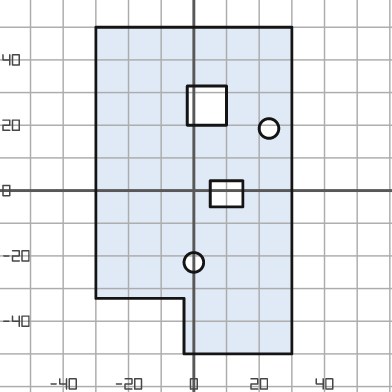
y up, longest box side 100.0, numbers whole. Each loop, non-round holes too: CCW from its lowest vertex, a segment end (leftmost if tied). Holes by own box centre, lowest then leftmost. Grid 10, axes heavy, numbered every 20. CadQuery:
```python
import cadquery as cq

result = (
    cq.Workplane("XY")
    .moveTo(-3.0, -50.0)
    .lineTo(30.0, -50.0)
    .lineTo(30.0, 50.0)
    .lineTo(-30.0, 50.0)
    .lineTo(-30.0, -33.0)
    .lineTo(-3.0, -33.0)
    .close()
    .moveTo(0.0, -22.0)
    .circle(3.0)
    .moveTo(5.0, -5.0)
    .lineTo(15.0, -5.0)
    .lineTo(15.0, 3.0)
    .lineTo(5.0, 3.0)
    .close()
    .moveTo(23.0, 19.0)
    .circle(3.0)
    .moveTo(-2.0, 20.0)
    .lineTo(10.0, 20.0)
    .lineTo(10.0, 32.0)
    .lineTo(-2.0, 32.0)
    .close()
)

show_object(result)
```